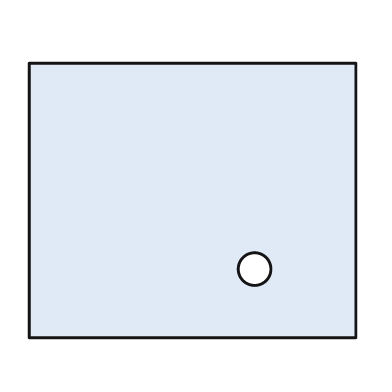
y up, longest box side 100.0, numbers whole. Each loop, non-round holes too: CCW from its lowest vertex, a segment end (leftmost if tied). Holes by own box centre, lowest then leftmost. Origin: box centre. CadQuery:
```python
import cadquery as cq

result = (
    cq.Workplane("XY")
    .moveTo(-50.0, -42.0)
    .lineTo(50.0, -42.0)
    .lineTo(50.0, 42.0)
    .lineTo(-50.0, 42.0)
    .close()
    .moveTo(19.0, -21.0)
    .circle(5.0)
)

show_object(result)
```